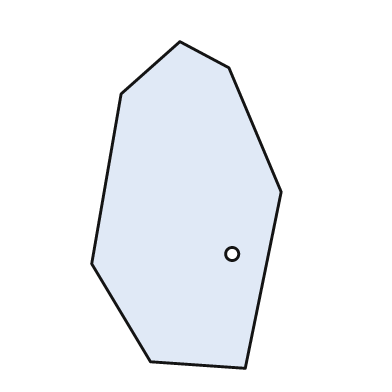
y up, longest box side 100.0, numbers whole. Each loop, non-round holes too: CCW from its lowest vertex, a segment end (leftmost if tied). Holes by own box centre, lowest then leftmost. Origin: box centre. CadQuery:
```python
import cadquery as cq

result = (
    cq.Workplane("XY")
    .moveTo(18.0, -50.0)
    .lineTo(29.0, 4.0)
    .lineTo(13.0, 42.0)
    .lineTo(-2.0, 50.0)
    .lineTo(-20.0, 34.0)
    .lineTo(-29.0, -18.0)
    .lineTo(-11.0, -48.0)
    .close()
    .moveTo(14.0, -15.0)
    .circle(2.0)
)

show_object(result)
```